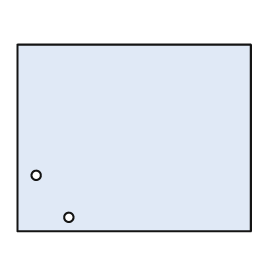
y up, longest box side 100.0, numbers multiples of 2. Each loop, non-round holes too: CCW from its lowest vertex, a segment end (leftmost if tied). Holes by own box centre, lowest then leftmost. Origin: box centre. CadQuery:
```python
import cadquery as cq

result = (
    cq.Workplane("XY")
    .moveTo(-50.0, -40.0)
    .lineTo(50.0, -40.0)
    .lineTo(50.0, 40.0)
    .lineTo(-50.0, 40.0)
    .close()
    .moveTo(-28.0, -34.0)
    .circle(2.0)
    .moveTo(-42.0, -16.0)
    .circle(2.0)
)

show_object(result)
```